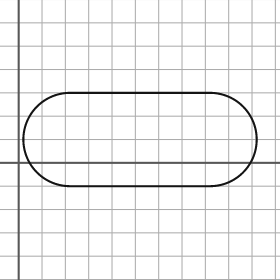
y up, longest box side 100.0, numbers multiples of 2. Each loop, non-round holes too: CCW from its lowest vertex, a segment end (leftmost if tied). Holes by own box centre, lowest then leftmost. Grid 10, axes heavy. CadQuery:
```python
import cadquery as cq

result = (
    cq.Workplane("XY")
    .moveTo(22.0, -10.0)
    .lineTo(82.0, -10.0)
    .threePointArc((102.0, 10.0), (82.0, 30.0))
    .lineTo(22.0, 30.0)
    .threePointArc((2.0, 10.0), (22.0, -10.0))
    .close()
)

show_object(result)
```